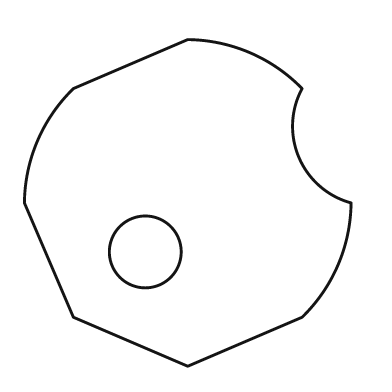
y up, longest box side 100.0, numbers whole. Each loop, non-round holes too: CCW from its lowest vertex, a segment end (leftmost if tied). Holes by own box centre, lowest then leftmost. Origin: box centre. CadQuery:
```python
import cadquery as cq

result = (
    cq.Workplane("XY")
    .moveTo(0.0, -50.0)
    .lineTo(35.0, -35.0)
    .threePointArc((46.0, -19.0), (50.0, 0.0))
    .threePointArc((34.0, 14.0), (35.0, 35.0))
    .threePointArc((19.0, 46.0), (0.0, 50.0))
    .lineTo(-35.0, 35.0)
    .threePointArc((-46.0, 19.0), (-50.0, 0.0))
    .lineTo(-35.0, -35.0)
    .close()
    .moveTo(-13.0, -15.0)
    .circle(11.0)
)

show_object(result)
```